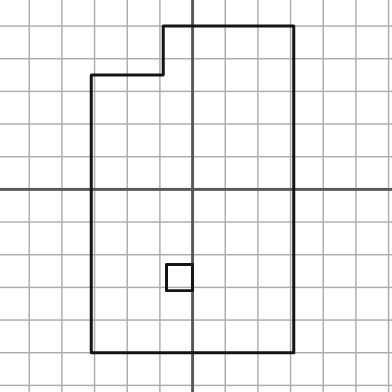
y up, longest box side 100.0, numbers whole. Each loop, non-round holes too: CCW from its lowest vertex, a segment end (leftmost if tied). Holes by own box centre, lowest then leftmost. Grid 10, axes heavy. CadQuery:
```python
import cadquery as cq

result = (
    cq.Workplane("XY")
    .moveTo(-31.0, -50.0)
    .lineTo(31.0, -50.0)
    .lineTo(31.0, 50.0)
    .lineTo(-9.0, 50.0)
    .lineTo(-9.0, 35.0)
    .lineTo(-31.0, 35.0)
    .close()
    .moveTo(-8.0, -31.0)
    .lineTo(0.0, -31.0)
    .lineTo(0.0, -23.0)
    .lineTo(-8.0, -23.0)
    .close()
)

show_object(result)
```